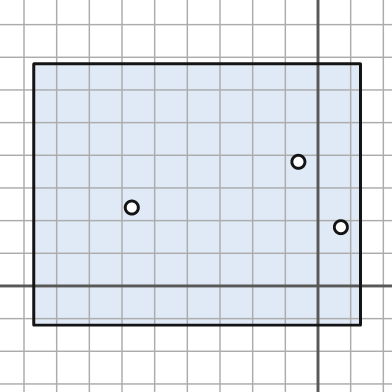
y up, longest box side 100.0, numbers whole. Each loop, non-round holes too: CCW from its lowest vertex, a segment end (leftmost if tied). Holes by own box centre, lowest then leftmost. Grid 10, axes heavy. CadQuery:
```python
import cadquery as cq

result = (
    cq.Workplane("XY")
    .moveTo(-87.0, -12.0)
    .lineTo(13.0, -12.0)
    .lineTo(13.0, 68.0)
    .lineTo(-87.0, 68.0)
    .close()
    .moveTo(7.0, 18.0)
    .circle(2.0)
    .moveTo(-57.0, 24.0)
    .circle(2.0)
    .moveTo(-6.0, 38.0)
    .circle(2.0)
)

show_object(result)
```